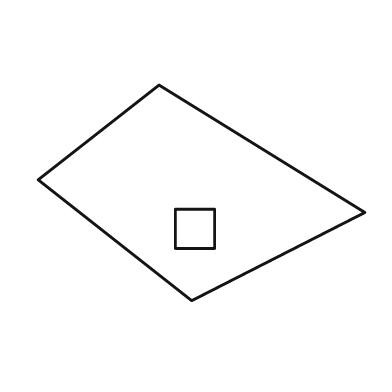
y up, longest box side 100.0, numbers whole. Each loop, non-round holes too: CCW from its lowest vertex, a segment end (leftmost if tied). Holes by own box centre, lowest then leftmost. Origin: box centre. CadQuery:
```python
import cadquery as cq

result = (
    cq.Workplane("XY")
    .moveTo(-3.0, -33.0)
    .lineTo(50.0, -6.0)
    .lineTo(-13.0, 33.0)
    .lineTo(-50.0, 4.0)
    .close()
    .moveTo(-8.0, -17.0)
    .lineTo(4.0, -17.0)
    .lineTo(4.0, -5.0)
    .lineTo(-8.0, -5.0)
    .close()
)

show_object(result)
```